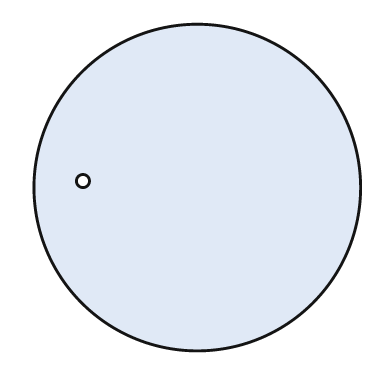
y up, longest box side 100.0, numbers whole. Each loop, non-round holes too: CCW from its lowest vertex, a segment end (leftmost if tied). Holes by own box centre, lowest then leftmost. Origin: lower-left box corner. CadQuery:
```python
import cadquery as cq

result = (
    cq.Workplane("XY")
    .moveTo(50.0, 50.0)
    .circle(50.0)
    .moveTo(15.0, 52.0)
    .circle(2.0)
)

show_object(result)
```